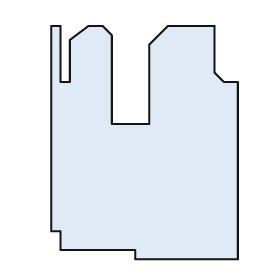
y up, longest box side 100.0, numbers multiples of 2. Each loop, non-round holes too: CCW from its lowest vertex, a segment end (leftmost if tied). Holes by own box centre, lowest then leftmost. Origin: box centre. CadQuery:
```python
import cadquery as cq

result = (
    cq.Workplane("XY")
    .moveTo(-4.0, -50.0)
    .lineTo(40.0, -50.0)
    .lineTo(40.0, 26.0)
    .lineTo(34.0, 26.0)
    .lineTo(30.0, 30.0)
    .lineTo(30.0, 50.0)
    .lineTo(10.0, 50.0)
    .lineTo(2.0, 42.0)
    .lineTo(2.0, 8.0)
    .lineTo(-14.0, 8.0)
    .lineTo(-14.0, 46.0)
    .lineTo(-18.0, 50.0)
    .lineTo(-24.0, 50.0)
    .lineTo(-32.0, 44.0)
    .lineTo(-32.0, 26.0)
    .lineTo(-36.0, 26.0)
    .lineTo(-36.0, 50.0)
    .lineTo(-40.0, 50.0)
    .lineTo(-40.0, -38.0)
    .lineTo(-36.0, -38.0)
    .lineTo(-36.0, -46.0)
    .lineTo(-4.0, -46.0)
    .close()
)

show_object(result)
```